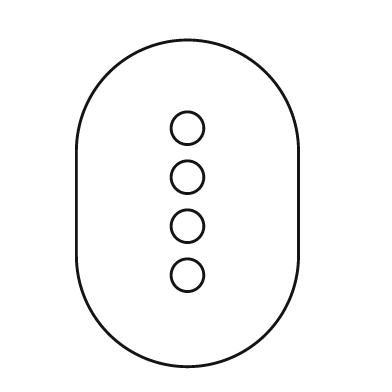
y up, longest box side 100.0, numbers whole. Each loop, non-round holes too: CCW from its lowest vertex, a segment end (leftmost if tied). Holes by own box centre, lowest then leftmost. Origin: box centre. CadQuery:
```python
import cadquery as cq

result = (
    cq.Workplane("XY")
    .moveTo(-34.0, -16.0)
    .threePointArc((0.0, -50.0), (34.0, -16.0))
    .lineTo(34.0, 16.0)
    .threePointArc((0.0, 50.0), (-34.0, 16.0))
    .close()
    .moveTo(0.0, -22.0)
    .circle(5.0)
    .moveTo(0.0, -7.0)
    .circle(5.0)
    .moveTo(0.0, 8.0)
    .circle(5.0)
    .moveTo(0.0, 23.0)
    .circle(5.0)
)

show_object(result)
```